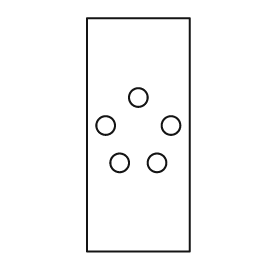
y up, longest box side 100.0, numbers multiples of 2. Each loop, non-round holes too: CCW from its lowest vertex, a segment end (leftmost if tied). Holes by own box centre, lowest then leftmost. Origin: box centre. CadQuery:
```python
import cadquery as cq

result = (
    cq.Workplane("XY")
    .moveTo(-22.0, -50.0)
    .lineTo(22.0, -50.0)
    .lineTo(22.0, 50.0)
    .lineTo(-22.0, 50.0)
    .close()
    .moveTo(-8.0, -12.0)
    .circle(4.0)
    .moveTo(8.0, -12.0)
    .circle(4.0)
    .moveTo(-14.0, 4.0)
    .circle(4.0)
    .moveTo(14.0, 4.0)
    .circle(4.0)
    .moveTo(0.0, 16.0)
    .circle(4.0)
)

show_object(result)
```